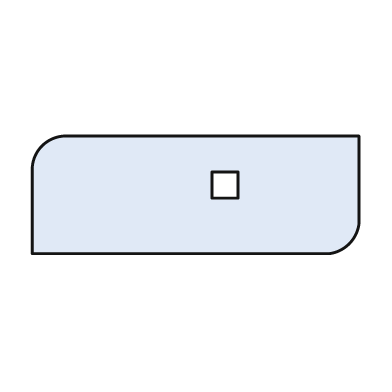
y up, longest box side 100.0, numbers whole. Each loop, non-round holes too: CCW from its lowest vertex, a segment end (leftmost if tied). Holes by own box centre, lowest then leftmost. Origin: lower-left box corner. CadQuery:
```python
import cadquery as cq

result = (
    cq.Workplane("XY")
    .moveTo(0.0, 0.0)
    .lineTo(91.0, 0.0)
    .threePointArc((97.0, 3.0), (100.0, 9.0))
    .lineTo(100.0, 36.0)
    .lineTo(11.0, 36.0)
    .threePointArc((3.0, 33.0), (0.0, 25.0))
    .close()
    .moveTo(55.0, 17.0)
    .lineTo(63.0, 17.0)
    .lineTo(63.0, 25.0)
    .lineTo(55.0, 25.0)
    .close()
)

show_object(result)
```